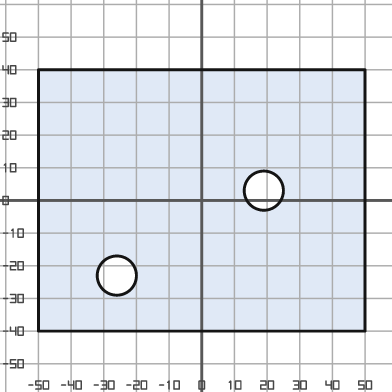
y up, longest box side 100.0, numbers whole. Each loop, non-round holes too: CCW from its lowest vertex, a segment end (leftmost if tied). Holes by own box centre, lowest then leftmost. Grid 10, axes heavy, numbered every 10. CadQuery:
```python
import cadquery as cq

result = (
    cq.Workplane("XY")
    .moveTo(-50.0, -40.0)
    .lineTo(50.0, -40.0)
    .lineTo(50.0, 40.0)
    .lineTo(-50.0, 40.0)
    .close()
    .moveTo(-26.0, -23.0)
    .circle(6.0)
    .moveTo(19.0, 3.0)
    .circle(6.0)
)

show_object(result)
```